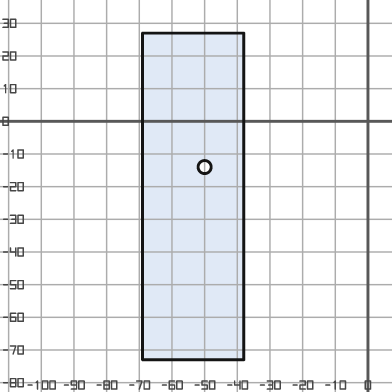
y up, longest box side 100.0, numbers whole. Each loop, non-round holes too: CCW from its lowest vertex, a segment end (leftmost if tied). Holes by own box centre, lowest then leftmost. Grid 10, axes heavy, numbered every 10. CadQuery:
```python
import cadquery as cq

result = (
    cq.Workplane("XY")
    .moveTo(-69.0, -73.0)
    .lineTo(-38.0, -73.0)
    .lineTo(-38.0, 27.0)
    .lineTo(-69.0, 27.0)
    .close()
    .moveTo(-50.0, -14.0)
    .circle(2.0)
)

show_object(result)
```